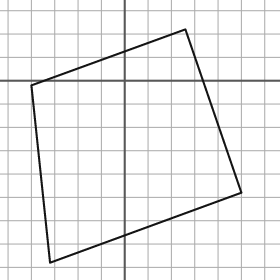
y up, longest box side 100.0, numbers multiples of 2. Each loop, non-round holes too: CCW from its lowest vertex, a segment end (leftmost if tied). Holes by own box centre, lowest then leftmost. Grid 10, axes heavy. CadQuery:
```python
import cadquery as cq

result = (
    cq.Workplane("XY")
    .moveTo(-32.0, -78.0)
    .lineTo(50.0, -48.0)
    .lineTo(26.0, 22.0)
    .lineTo(-40.0, -2.0)
    .close()
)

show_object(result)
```